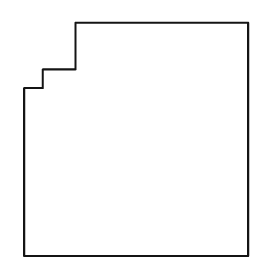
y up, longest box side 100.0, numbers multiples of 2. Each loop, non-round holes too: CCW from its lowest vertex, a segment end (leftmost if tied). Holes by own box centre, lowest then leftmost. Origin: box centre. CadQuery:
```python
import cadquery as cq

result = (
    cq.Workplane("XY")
    .moveTo(-48.0, -50.0)
    .lineTo(48.0, -50.0)
    .lineTo(48.0, 50.0)
    .lineTo(-26.0, 50.0)
    .lineTo(-26.0, 30.0)
    .lineTo(-40.0, 30.0)
    .lineTo(-40.0, 22.0)
    .lineTo(-48.0, 22.0)
    .close()
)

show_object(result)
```